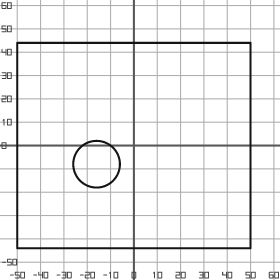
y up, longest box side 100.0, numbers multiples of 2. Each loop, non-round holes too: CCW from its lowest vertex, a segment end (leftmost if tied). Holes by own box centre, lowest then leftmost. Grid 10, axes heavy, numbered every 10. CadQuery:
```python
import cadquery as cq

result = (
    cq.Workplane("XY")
    .moveTo(-50.0, -44.0)
    .lineTo(50.0, -44.0)
    .lineTo(50.0, 44.0)
    .lineTo(-50.0, 44.0)
    .close()
    .moveTo(-16.0, -8.0)
    .circle(10.0)
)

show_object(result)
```